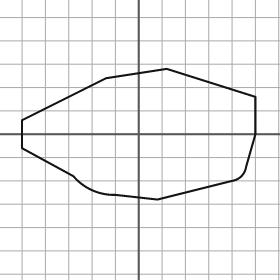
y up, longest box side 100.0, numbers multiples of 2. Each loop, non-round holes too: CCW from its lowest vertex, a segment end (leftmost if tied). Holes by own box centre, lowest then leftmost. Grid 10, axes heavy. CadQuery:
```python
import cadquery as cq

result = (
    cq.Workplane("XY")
    .moveTo(8.0, -28.0)
    .lineTo(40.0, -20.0)
    .threePointArc((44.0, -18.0), (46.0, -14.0))
    .lineTo(50.0, 0.0)
    .lineTo(50.0, 16.0)
    .lineTo(12.0, 28.0)
    .lineTo(-14.0, 24.0)
    .lineTo(-50.0, 6.0)
    .lineTo(-50.0, -6.0)
    .lineTo(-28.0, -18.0)
    .threePointArc((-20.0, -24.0), (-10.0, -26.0))
    .close()
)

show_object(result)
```